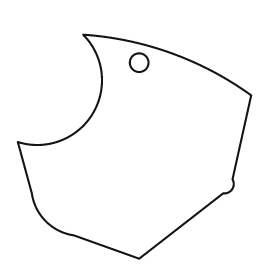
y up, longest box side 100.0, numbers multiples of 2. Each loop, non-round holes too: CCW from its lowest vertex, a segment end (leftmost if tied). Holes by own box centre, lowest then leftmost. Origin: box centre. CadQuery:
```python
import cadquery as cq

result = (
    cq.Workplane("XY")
    .moveTo(2.0, -48.0)
    .lineTo(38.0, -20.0)
    .threePointArc((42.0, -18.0), (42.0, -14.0))
    .lineTo(50.0, 22.0)
    .threePointArc((16.0, 40.0), (-22.0, 48.0))
    .threePointArc((-18.0, 14.0), (-50.0, 2.0))
    .lineTo(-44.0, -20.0)
    .threePointArc((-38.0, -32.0), (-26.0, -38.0))
    .close()
    .moveTo(2.0, 36.0)
    .circle(4.0)
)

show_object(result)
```